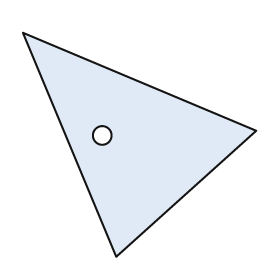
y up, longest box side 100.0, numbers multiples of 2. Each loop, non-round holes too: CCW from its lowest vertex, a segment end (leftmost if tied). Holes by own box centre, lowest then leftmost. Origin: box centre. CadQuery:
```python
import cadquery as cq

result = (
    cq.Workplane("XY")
    .moveTo(-10.0, -48.0)
    .lineTo(50.0, 6.0)
    .lineTo(-50.0, 48.0)
    .close()
    .moveTo(-16.0, 4.0)
    .circle(4.0)
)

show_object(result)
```